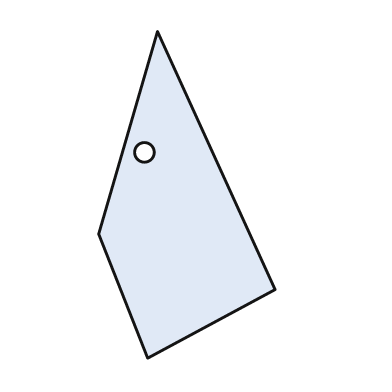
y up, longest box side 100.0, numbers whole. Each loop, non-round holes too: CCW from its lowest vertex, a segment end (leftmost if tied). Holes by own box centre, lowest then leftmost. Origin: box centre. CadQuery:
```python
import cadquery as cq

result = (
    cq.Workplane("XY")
    .moveTo(-12.0, -50.0)
    .lineTo(27.0, -29.0)
    .lineTo(-9.0, 50.0)
    .lineTo(-27.0, -12.0)
    .close()
    .moveTo(-13.0, 13.0)
    .circle(3.0)
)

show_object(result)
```